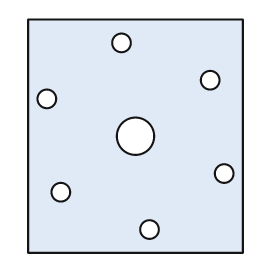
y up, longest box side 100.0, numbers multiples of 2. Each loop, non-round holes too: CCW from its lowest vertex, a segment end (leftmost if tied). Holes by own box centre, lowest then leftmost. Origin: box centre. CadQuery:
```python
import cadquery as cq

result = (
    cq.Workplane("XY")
    .moveTo(-46.0, -50.0)
    .lineTo(46.0, -50.0)
    .lineTo(46.0, 50.0)
    .lineTo(-46.0, 50.0)
    .close()
    .moveTo(6.0, -40.0)
    .circle(4.0)
    .moveTo(-32.0, -24.0)
    .circle(4.0)
    .moveTo(38.0, -16.0)
    .circle(4.0)
    .moveTo(0.0, 0.0)
    .circle(8.0)
    .moveTo(-38.0, 16.0)
    .circle(4.0)
    .moveTo(32.0, 24.0)
    .circle(4.0)
    .moveTo(-6.0, 40.0)
    .circle(4.0)
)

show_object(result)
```